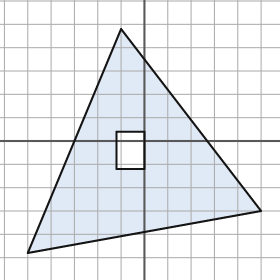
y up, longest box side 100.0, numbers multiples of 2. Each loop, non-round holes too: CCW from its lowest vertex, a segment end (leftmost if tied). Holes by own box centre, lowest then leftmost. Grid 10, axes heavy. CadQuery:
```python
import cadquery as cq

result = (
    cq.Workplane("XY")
    .moveTo(-50.0, -48.0)
    .lineTo(50.0, -30.0)
    .lineTo(-10.0, 48.0)
    .close()
    .moveTo(-12.0, -12.0)
    .lineTo(0.0, -12.0)
    .lineTo(0.0, 4.0)
    .lineTo(-12.0, 4.0)
    .close()
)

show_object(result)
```